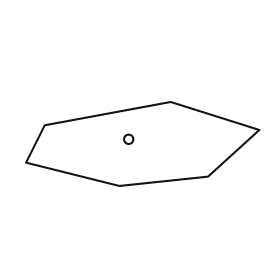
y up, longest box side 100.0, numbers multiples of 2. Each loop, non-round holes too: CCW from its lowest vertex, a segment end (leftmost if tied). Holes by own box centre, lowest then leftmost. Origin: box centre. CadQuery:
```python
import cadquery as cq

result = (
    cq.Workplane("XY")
    .moveTo(-10.0, -18.0)
    .lineTo(28.0, -14.0)
    .lineTo(50.0, 6.0)
    .lineTo(12.0, 18.0)
    .lineTo(-42.0, 8.0)
    .lineTo(-50.0, -8.0)
    .close()
    .moveTo(-6.0, 2.0)
    .circle(2.0)
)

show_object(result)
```